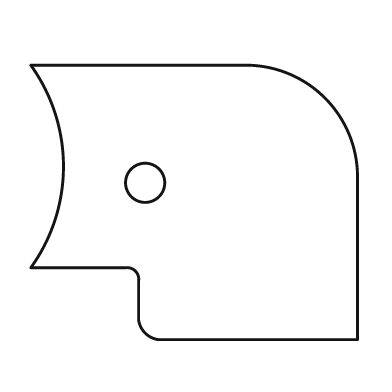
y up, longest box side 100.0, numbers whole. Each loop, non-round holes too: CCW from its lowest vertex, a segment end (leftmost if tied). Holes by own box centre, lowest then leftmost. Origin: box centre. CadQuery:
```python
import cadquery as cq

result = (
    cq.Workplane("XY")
    .moveTo(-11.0, -42.0)
    .lineTo(50.0, -42.0)
    .lineTo(50.0, 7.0)
    .threePointArc((40.0, 32.0), (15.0, 42.0))
    .lineTo(-50.0, 42.0)
    .threePointArc((-40.0, 11.0), (-50.0, -20.0))
    .lineTo(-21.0, -20.0)
    .threePointArc((-18.0, -21.0), (-17.0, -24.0))
    .lineTo(-17.0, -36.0)
    .threePointArc((-15.0, -40.0), (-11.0, -42.0))
    .close()
    .moveTo(-15.0, 6.0)
    .circle(6.0)
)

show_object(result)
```